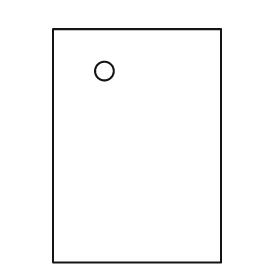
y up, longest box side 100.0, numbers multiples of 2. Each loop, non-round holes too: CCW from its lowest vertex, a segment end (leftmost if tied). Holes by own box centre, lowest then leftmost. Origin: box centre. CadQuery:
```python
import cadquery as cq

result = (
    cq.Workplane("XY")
    .moveTo(-36.0, -50.0)
    .lineTo(36.0, -50.0)
    .lineTo(36.0, 50.0)
    .lineTo(-36.0, 50.0)
    .close()
    .moveTo(-14.0, 32.0)
    .circle(4.0)
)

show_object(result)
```